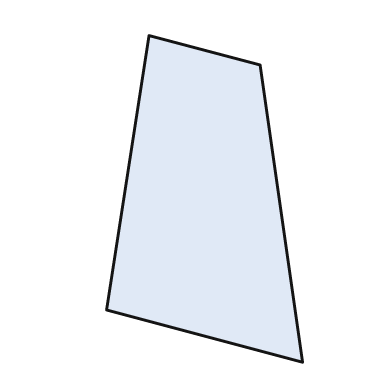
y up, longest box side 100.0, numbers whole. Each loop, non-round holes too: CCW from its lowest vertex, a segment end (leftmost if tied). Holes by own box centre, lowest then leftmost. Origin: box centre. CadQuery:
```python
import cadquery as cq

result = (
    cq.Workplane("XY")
    .moveTo(30.0, -50.0)
    .lineTo(17.0, 41.0)
    .lineTo(-17.0, 50.0)
    .lineTo(-30.0, -34.0)
    .close()
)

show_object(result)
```